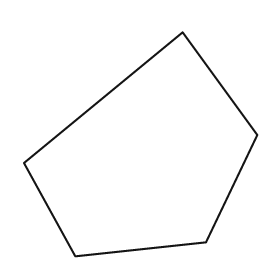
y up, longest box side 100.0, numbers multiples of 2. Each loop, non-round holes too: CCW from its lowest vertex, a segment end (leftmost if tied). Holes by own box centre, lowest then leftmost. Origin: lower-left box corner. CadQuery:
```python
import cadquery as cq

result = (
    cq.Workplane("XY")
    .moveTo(22.0, 0.0)
    .lineTo(78.0, 6.0)
    .lineTo(100.0, 52.0)
    .lineTo(68.0, 96.0)
    .lineTo(0.0, 40.0)
    .close()
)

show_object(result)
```